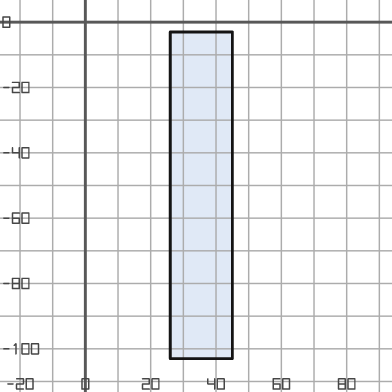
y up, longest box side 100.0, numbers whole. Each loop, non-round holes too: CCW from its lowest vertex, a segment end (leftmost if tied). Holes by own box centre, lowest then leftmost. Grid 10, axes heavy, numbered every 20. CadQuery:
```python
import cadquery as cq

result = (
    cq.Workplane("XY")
    .moveTo(26.0, -103.0)
    .lineTo(45.0, -103.0)
    .lineTo(45.0, -3.0)
    .lineTo(26.0, -3.0)
    .close()
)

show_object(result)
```